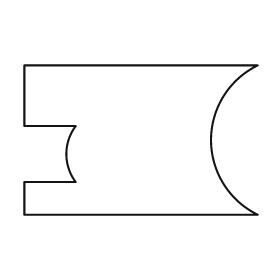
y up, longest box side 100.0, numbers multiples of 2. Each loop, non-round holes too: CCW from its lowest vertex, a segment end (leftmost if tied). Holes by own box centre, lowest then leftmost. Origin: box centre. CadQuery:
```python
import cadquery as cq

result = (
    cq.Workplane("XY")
    .moveTo(-50.0, -32.0)
    .lineTo(50.0, -32.0)
    .threePointArc((30.0, 0.0), (50.0, 32.0))
    .lineTo(-50.0, 32.0)
    .lineTo(-50.0, 6.0)
    .lineTo(-28.0, 6.0)
    .threePointArc((-32.0, -6.0), (-28.0, -18.0))
    .lineTo(-50.0, -18.0)
    .close()
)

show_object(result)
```